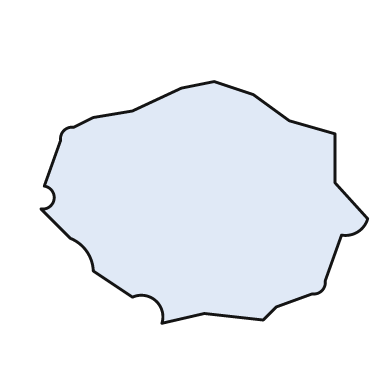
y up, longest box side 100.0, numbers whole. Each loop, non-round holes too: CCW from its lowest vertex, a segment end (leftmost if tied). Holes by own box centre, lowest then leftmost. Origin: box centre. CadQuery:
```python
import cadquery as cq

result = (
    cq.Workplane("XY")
    .moveTo(-13.0, -37.0)
    .lineTo(0.0, -34.0)
    .lineTo(18.0, -36.0)
    .lineTo(22.0, -32.0)
    .lineTo(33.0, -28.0)
    .threePointArc((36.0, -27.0), (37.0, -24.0))
    .lineTo(42.0, -10.0)
    .threePointArc((47.0, -9.0), (50.0, -5.0))
    .lineTo(40.0, 6.0)
    .lineTo(40.0, 21.0)
    .lineTo(26.0, 25.0)
    .lineTo(15.0, 33.0)
    .lineTo(3.0, 37.0)
    .lineTo(-7.0, 35.0)
    .lineTo(-22.0, 28.0)
    .lineTo(-34.0, 26.0)
    .lineTo(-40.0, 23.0)
    .threePointArc((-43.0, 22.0), (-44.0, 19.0))
    .lineTo(-49.0, 5.0)
    .threePointArc((-46.0, 1.0), (-50.0, -2.0))
    .lineTo(-41.0, -11.0)
    .threePointArc((-36.0, -15.0), (-34.0, -21.0))
    .lineTo(-22.0, -29.0)
    .threePointArc((-15.0, -30.0), (-13.0, -37.0))
    .close()
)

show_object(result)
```